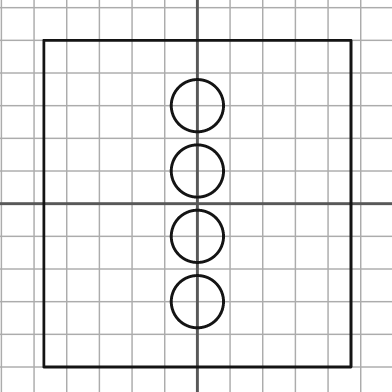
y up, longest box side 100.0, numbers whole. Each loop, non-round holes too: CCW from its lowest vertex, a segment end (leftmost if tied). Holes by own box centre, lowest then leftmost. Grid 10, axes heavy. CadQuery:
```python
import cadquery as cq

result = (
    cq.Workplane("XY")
    .moveTo(-47.0, -50.0)
    .lineTo(47.0, -50.0)
    .lineTo(47.0, 50.0)
    .lineTo(-47.0, 50.0)
    .close()
    .moveTo(0.0, -30.0)
    .circle(8.0)
    .moveTo(0.0, -10.0)
    .circle(8.0)
    .moveTo(0.0, 10.0)
    .circle(8.0)
    .moveTo(0.0, 30.0)
    .circle(8.0)
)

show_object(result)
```